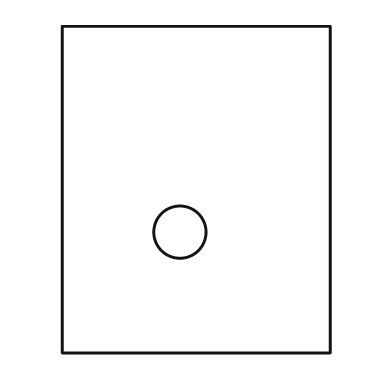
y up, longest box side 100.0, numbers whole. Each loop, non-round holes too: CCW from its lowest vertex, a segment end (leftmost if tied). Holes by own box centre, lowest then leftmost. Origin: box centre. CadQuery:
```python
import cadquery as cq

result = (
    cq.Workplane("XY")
    .moveTo(-41.0, -50.0)
    .lineTo(41.0, -50.0)
    .lineTo(41.0, 50.0)
    .lineTo(-41.0, 50.0)
    .close()
    .moveTo(-5.0, -13.0)
    .circle(8.0)
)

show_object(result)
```